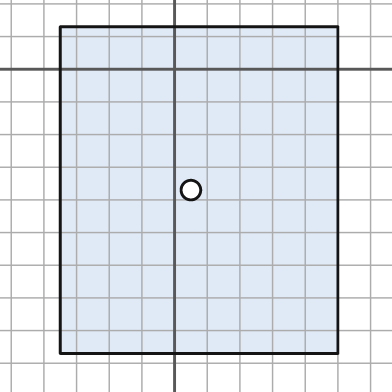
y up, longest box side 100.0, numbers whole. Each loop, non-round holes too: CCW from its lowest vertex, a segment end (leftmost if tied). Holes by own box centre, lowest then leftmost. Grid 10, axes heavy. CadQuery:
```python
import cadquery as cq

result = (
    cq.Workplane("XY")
    .moveTo(-35.0, -87.0)
    .lineTo(50.0, -87.0)
    .lineTo(50.0, 13.0)
    .lineTo(-35.0, 13.0)
    .close()
    .moveTo(5.0, -37.0)
    .circle(3.0)
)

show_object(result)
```